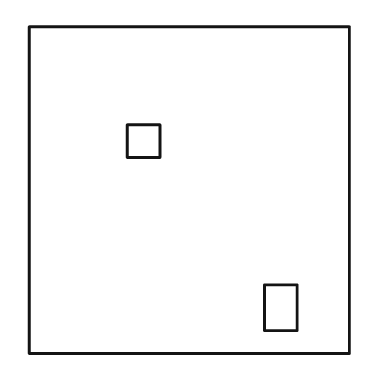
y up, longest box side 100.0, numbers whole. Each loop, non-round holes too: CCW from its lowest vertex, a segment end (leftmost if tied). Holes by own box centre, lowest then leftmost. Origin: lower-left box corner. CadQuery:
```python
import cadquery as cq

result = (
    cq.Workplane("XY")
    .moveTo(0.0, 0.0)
    .lineTo(98.0, 0.0)
    .lineTo(98.0, 100.0)
    .lineTo(0.0, 100.0)
    .close()
    .moveTo(72.0, 7.0)
    .lineTo(82.0, 7.0)
    .lineTo(82.0, 21.0)
    .lineTo(72.0, 21.0)
    .close()
    .moveTo(30.0, 60.0)
    .lineTo(40.0, 60.0)
    .lineTo(40.0, 70.0)
    .lineTo(30.0, 70.0)
    .close()
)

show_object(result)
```